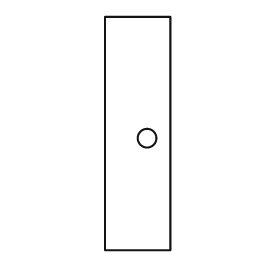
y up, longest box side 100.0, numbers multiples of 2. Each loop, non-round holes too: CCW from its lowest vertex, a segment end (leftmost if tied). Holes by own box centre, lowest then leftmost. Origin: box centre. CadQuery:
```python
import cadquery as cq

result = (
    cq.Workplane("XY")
    .moveTo(-14.0, -50.0)
    .lineTo(14.0, -50.0)
    .lineTo(14.0, 50.0)
    .lineTo(-14.0, 50.0)
    .close()
    .moveTo(4.0, -2.0)
    .circle(4.0)
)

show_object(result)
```